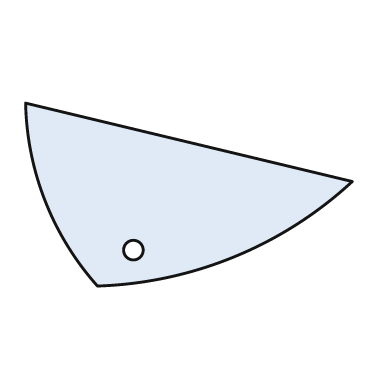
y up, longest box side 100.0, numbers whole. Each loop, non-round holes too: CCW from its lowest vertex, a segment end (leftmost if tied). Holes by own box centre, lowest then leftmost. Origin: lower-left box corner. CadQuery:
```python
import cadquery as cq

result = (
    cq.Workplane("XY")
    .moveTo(22.0, 0.0)
    .threePointArc((64.0, 9.0), (100.0, 32.0))
    .lineTo(0.0, 56.0)
    .threePointArc((6.0, 26.0), (22.0, 0.0))
    .close()
    .moveTo(33.0, 11.0)
    .circle(3.0)
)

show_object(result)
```